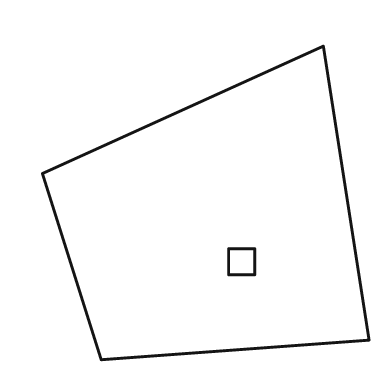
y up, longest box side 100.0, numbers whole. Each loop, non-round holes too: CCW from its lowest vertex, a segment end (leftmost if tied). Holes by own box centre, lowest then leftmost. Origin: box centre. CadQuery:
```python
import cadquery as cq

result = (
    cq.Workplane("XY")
    .moveTo(-32.0, -48.0)
    .lineTo(50.0, -42.0)
    .lineTo(36.0, 48.0)
    .lineTo(-50.0, 9.0)
    .close()
    .moveTo(7.0, -22.0)
    .lineTo(15.0, -22.0)
    .lineTo(15.0, -14.0)
    .lineTo(7.0, -14.0)
    .close()
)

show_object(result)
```